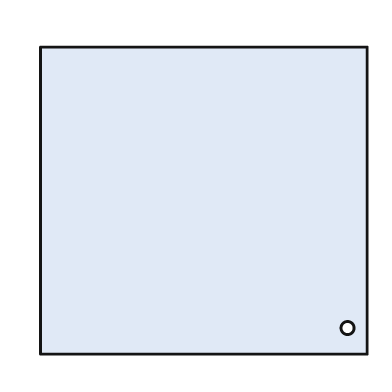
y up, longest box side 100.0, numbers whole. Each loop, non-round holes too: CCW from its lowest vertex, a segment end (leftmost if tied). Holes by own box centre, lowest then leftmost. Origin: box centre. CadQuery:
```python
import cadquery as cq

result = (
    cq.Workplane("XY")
    .moveTo(-50.0, -47.0)
    .lineTo(50.0, -47.0)
    .lineTo(50.0, 47.0)
    .lineTo(-50.0, 47.0)
    .close()
    .moveTo(44.0, -39.0)
    .circle(2.0)
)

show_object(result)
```